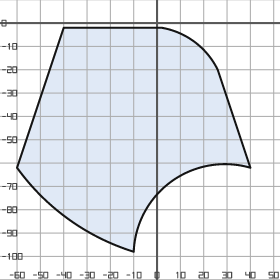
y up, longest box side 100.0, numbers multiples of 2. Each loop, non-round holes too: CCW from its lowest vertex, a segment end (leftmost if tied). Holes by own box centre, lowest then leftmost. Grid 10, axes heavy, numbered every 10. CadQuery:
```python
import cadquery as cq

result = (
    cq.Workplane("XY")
    .moveTo(-10.0, -98.0)
    .threePointArc((6.0, -68.0), (40.0, -62.0))
    .lineTo(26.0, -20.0)
    .threePointArc((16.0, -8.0), (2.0, -2.0))
    .lineTo(-40.0, -2.0)
    .lineTo(-60.0, -62.0)
    .threePointArc((-38.0, -84.0), (-10.0, -98.0))
    .close()
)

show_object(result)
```